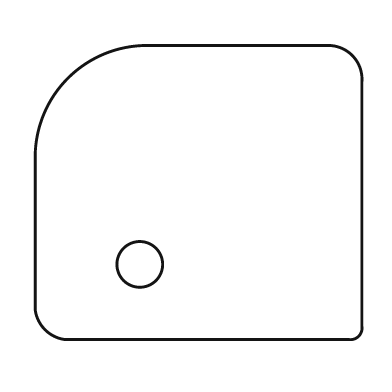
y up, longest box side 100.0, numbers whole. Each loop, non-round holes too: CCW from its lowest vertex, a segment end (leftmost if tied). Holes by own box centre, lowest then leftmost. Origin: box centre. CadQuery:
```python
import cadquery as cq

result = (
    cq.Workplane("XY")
    .moveTo(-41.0, -45.0)
    .lineTo(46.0, -45.0)
    .threePointArc((49.0, -44.0), (50.0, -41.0))
    .lineTo(50.0, 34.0)
    .threePointArc((47.0, 42.0), (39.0, 45.0))
    .lineTo(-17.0, 45.0)
    .threePointArc((-40.0, 35.0), (-50.0, 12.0))
    .lineTo(-50.0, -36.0)
    .threePointArc((-47.0, -42.0), (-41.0, -45.0))
    .close()
    .moveTo(-18.0, -22.0)
    .circle(7.0)
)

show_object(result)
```